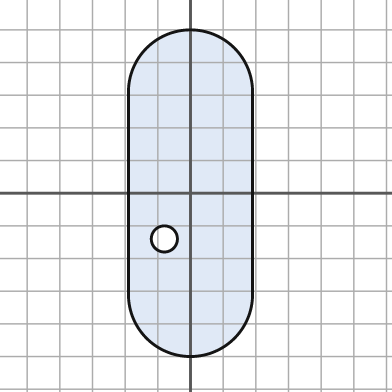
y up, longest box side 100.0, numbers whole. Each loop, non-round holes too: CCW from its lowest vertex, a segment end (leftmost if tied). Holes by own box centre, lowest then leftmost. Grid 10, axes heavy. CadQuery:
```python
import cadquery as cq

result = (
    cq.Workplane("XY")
    .moveTo(-19.0, -31.0)
    .threePointArc((0.0, -50.0), (19.0, -31.0))
    .lineTo(19.0, 31.0)
    .threePointArc((0.0, 50.0), (-19.0, 31.0))
    .close()
    .moveTo(-8.0, -14.0)
    .circle(4.0)
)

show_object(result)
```